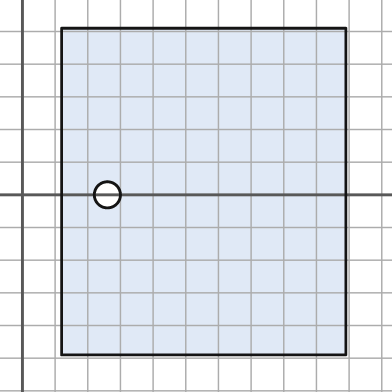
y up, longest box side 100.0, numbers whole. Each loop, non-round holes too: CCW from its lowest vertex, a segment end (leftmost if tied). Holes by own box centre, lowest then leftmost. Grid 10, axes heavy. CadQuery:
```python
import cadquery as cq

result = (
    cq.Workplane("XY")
    .moveTo(12.0, -49.0)
    .lineTo(99.0, -49.0)
    .lineTo(99.0, 51.0)
    .lineTo(12.0, 51.0)
    .close()
    .moveTo(26.0, 0.0)
    .circle(4.0)
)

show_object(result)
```